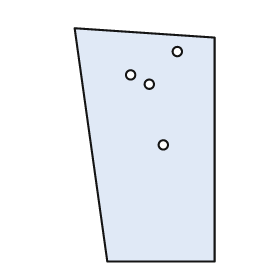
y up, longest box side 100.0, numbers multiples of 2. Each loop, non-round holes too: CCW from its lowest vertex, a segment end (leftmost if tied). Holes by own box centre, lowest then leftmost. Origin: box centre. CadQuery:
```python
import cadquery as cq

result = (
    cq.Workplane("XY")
    .moveTo(-16.0, -50.0)
    .lineTo(30.0, -50.0)
    .lineTo(30.0, 46.0)
    .lineTo(-30.0, 50.0)
    .close()
    .moveTo(8.0, 0.0)
    .circle(2.0)
    .moveTo(2.0, 26.0)
    .circle(2.0)
    .moveTo(-6.0, 30.0)
    .circle(2.0)
    .moveTo(14.0, 40.0)
    .circle(2.0)
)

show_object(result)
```